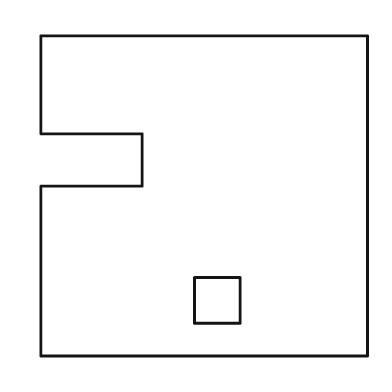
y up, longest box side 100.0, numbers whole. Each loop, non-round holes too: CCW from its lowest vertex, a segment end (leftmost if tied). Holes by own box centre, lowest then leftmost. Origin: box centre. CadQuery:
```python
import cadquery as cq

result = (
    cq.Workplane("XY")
    .moveTo(-50.0, -49.0)
    .lineTo(50.0, -49.0)
    .lineTo(50.0, 49.0)
    .lineTo(-50.0, 49.0)
    .lineTo(-50.0, 19.0)
    .lineTo(-19.0, 19.0)
    .lineTo(-19.0, 3.0)
    .lineTo(-50.0, 3.0)
    .close()
    .moveTo(-3.0, -39.0)
    .lineTo(11.0, -39.0)
    .lineTo(11.0, -25.0)
    .lineTo(-3.0, -25.0)
    .close()
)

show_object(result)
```